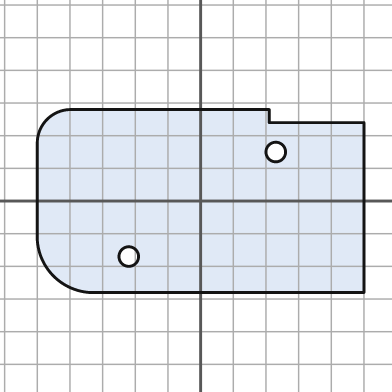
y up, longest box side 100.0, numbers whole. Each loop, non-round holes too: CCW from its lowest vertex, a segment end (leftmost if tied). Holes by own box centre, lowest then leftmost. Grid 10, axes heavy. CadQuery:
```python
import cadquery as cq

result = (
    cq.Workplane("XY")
    .moveTo(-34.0, -28.0)
    .lineTo(50.0, -28.0)
    .lineTo(50.0, 24.0)
    .lineTo(21.0, 24.0)
    .lineTo(21.0, 28.0)
    .lineTo(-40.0, 28.0)
    .threePointArc((-47.0, 25.0), (-50.0, 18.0))
    .lineTo(-50.0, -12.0)
    .threePointArc((-45.0, -23.0), (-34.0, -28.0))
    .close()
    .moveTo(-22.0, -17.0)
    .circle(3.0)
    .moveTo(23.0, 15.0)
    .circle(3.0)
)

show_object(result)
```